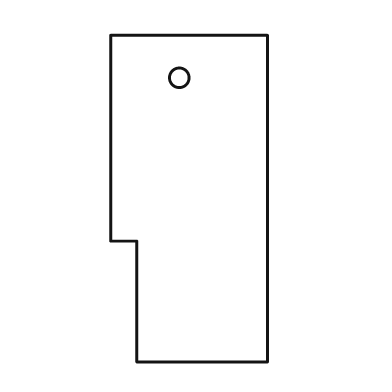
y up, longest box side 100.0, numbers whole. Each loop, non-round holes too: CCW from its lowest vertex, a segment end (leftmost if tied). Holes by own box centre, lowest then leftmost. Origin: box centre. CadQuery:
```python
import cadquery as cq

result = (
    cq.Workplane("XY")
    .moveTo(-16.0, -50.0)
    .lineTo(24.0, -50.0)
    .lineTo(24.0, 50.0)
    .lineTo(-24.0, 50.0)
    .lineTo(-24.0, -13.0)
    .lineTo(-16.0, -13.0)
    .close()
    .moveTo(-3.0, 37.0)
    .circle(3.0)
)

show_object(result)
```